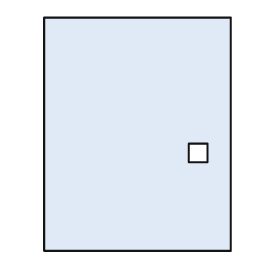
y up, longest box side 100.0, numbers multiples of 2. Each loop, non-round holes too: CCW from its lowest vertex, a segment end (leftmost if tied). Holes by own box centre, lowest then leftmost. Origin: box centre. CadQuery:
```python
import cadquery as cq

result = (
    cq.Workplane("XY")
    .moveTo(-40.0, -50.0)
    .lineTo(40.0, -50.0)
    .lineTo(40.0, 50.0)
    .lineTo(-40.0, 50.0)
    .close()
    .moveTo(22.0, -12.0)
    .lineTo(30.0, -12.0)
    .lineTo(30.0, -4.0)
    .lineTo(22.0, -4.0)
    .close()
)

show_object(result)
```